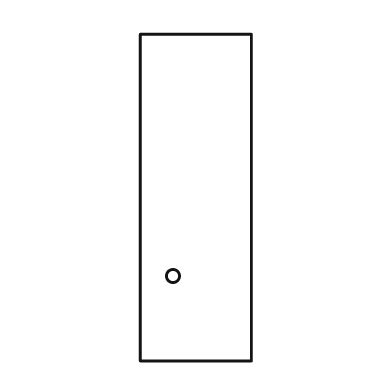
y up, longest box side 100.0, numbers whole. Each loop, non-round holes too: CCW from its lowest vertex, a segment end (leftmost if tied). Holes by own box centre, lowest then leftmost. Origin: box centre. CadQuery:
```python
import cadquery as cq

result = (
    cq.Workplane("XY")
    .moveTo(-17.0, -50.0)
    .lineTo(17.0, -50.0)
    .lineTo(17.0, 50.0)
    .lineTo(-17.0, 50.0)
    .close()
    .moveTo(-7.0, -24.0)
    .circle(2.0)
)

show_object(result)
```